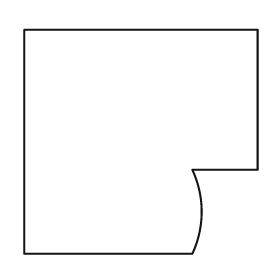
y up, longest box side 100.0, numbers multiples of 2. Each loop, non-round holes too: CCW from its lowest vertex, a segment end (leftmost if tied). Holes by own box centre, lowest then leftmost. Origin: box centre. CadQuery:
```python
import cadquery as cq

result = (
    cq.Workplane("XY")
    .moveTo(-50.0, -48.0)
    .lineTo(22.0, -48.0)
    .threePointArc((26.0, -30.0), (22.0, -12.0))
    .lineTo(50.0, -12.0)
    .lineTo(50.0, 48.0)
    .lineTo(-50.0, 48.0)
    .close()
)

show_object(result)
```